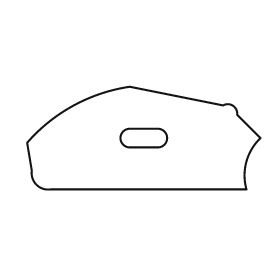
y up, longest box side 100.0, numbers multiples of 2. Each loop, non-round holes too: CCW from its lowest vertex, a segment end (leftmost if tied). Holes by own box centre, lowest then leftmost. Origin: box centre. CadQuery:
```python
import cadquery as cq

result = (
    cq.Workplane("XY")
    .moveTo(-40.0, -22.0)
    .lineTo(44.0, -22.0)
    .threePointArc((44.0, -10.0), (50.0, 0.0))
    .lineTo(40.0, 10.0)
    .threePointArc((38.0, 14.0), (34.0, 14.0))
    .lineTo(-6.0, 22.0)
    .threePointArc((-30.0, 14.0), (-50.0, -2.0))
    .lineTo(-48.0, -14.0)
    .threePointArc((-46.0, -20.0), (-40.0, -22.0))
    .close()
    .moveTo(-6.0, -4.0)
    .lineTo(6.0, -4.0)
    .threePointArc((10.0, 0.0), (6.0, 4.0))
    .lineTo(-6.0, 4.0)
    .threePointArc((-10.0, 0.0), (-6.0, -4.0))
    .close()
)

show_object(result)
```